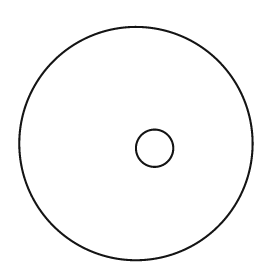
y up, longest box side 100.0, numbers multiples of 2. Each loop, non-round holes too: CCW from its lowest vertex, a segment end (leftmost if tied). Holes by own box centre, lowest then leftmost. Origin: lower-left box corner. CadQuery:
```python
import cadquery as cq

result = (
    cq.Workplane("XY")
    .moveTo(50.0, 50.0)
    .circle(50.0)
    .moveTo(58.0, 48.0)
    .circle(8.0)
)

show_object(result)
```